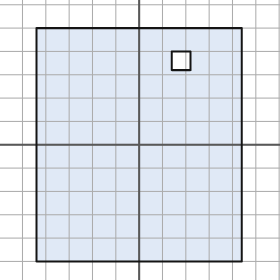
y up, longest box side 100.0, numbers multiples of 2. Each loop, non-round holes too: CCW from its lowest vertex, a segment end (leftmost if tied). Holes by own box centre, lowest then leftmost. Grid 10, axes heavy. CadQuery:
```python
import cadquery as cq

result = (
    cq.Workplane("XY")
    .moveTo(-44.0, -50.0)
    .lineTo(44.0, -50.0)
    .lineTo(44.0, 50.0)
    .lineTo(-44.0, 50.0)
    .close()
    .moveTo(14.0, 32.0)
    .lineTo(22.0, 32.0)
    .lineTo(22.0, 40.0)
    .lineTo(14.0, 40.0)
    .close()
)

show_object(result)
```